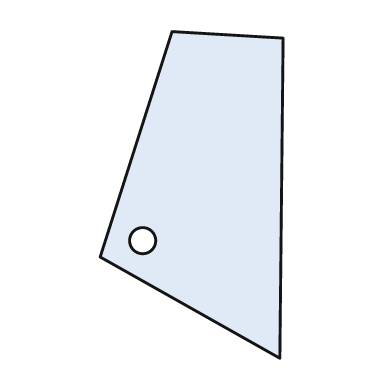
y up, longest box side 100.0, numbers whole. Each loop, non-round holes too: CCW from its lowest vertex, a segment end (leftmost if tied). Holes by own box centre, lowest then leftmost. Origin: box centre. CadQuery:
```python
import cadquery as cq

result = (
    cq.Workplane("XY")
    .moveTo(27.0, -50.0)
    .lineTo(28.0, 48.0)
    .lineTo(-6.0, 50.0)
    .lineTo(-28.0, -19.0)
    .close()
    .moveTo(-15.0, -14.0)
    .circle(4.0)
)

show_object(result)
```